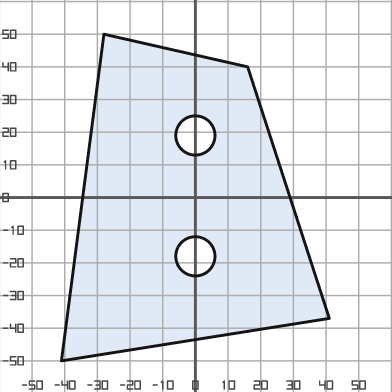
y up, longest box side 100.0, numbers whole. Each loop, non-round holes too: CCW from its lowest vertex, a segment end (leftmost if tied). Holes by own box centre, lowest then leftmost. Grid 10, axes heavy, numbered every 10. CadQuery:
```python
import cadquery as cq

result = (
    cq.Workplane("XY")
    .moveTo(-41.0, -50.0)
    .lineTo(41.0, -37.0)
    .lineTo(16.0, 40.0)
    .lineTo(-28.0, 50.0)
    .close()
    .moveTo(0.0, -18.0)
    .circle(6.0)
    .moveTo(0.0, 19.0)
    .circle(6.0)
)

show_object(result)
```